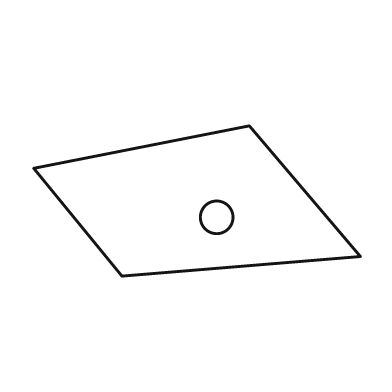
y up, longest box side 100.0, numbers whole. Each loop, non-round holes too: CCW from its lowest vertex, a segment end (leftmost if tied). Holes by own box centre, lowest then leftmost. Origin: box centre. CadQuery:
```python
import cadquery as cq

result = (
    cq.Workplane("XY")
    .moveTo(-23.0, -23.0)
    .lineTo(50.0, -17.0)
    .lineTo(16.0, 23.0)
    .lineTo(-50.0, 10.0)
    .close()
    .moveTo(6.0, -5.0)
    .circle(5.0)
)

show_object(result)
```